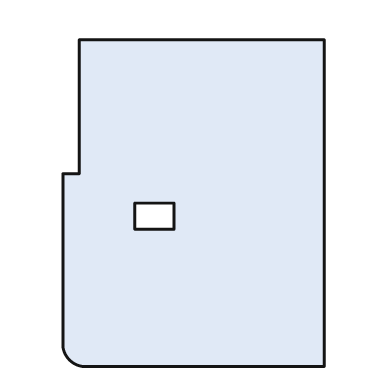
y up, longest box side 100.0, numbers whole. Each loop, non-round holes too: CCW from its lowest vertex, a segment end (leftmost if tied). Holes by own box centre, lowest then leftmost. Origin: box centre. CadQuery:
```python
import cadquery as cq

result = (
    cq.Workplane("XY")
    .moveTo(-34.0, -50.0)
    .lineTo(40.0, -50.0)
    .lineTo(40.0, 50.0)
    .lineTo(-35.0, 50.0)
    .lineTo(-35.0, 9.0)
    .lineTo(-40.0, 9.0)
    .lineTo(-40.0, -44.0)
    .threePointArc((-38.0, -48.0), (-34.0, -50.0))
    .close()
    .moveTo(-18.0, -8.0)
    .lineTo(-6.0, -8.0)
    .lineTo(-6.0, 0.0)
    .lineTo(-18.0, 0.0)
    .close()
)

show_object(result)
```